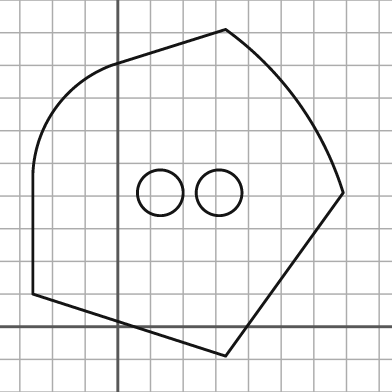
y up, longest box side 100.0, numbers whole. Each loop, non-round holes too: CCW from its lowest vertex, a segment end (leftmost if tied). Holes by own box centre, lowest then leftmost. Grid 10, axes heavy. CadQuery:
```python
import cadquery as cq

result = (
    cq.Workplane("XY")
    .moveTo(33.0, -9.0)
    .lineTo(69.0, 41.0)
    .threePointArc((55.0, 69.0), (33.0, 91.0))
    .lineTo(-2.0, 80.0)
    .threePointArc((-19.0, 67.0), (-26.0, 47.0))
    .lineTo(-26.0, 10.0)
    .close()
    .moveTo(13.0, 41.0)
    .circle(7.0)
    .moveTo(31.0, 41.0)
    .circle(7.0)
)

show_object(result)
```